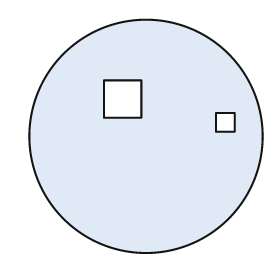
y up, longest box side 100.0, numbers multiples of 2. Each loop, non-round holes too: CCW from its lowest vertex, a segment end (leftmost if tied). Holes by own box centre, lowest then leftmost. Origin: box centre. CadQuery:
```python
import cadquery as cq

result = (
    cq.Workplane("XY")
    .moveTo(0.0, 0.0)
    .circle(50.0)
    .moveTo(30.0, 2.0)
    .lineTo(38.0, 2.0)
    .lineTo(38.0, 10.0)
    .lineTo(30.0, 10.0)
    .close()
    .moveTo(-18.0, 8.0)
    .lineTo(-2.0, 8.0)
    .lineTo(-2.0, 24.0)
    .lineTo(-18.0, 24.0)
    .close()
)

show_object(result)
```